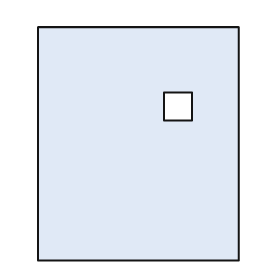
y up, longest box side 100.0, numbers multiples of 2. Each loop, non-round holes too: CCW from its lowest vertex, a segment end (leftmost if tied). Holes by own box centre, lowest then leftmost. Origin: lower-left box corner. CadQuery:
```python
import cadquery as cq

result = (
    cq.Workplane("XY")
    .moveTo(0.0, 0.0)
    .lineTo(86.0, 0.0)
    .lineTo(86.0, 100.0)
    .lineTo(0.0, 100.0)
    .close()
    .moveTo(54.0, 60.0)
    .lineTo(66.0, 60.0)
    .lineTo(66.0, 72.0)
    .lineTo(54.0, 72.0)
    .close()
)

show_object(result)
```